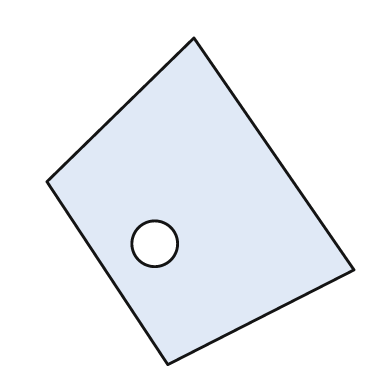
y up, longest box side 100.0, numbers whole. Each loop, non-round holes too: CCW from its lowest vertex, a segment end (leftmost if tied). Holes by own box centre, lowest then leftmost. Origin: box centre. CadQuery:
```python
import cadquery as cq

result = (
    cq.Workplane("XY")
    .moveTo(-10.0, -50.0)
    .lineTo(47.0, -21.0)
    .lineTo(-2.0, 50.0)
    .lineTo(-47.0, 6.0)
    .close()
    .moveTo(-14.0, -13.0)
    .circle(7.0)
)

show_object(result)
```